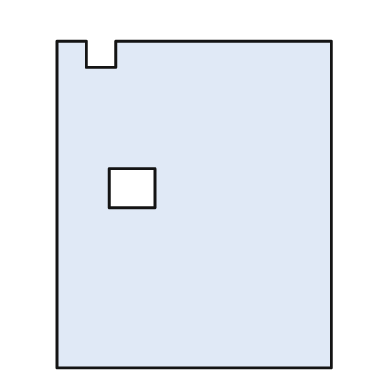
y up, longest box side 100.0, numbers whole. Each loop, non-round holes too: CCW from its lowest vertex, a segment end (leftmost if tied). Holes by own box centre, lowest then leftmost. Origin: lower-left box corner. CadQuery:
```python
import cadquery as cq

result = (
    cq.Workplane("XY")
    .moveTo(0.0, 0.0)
    .lineTo(84.0, 0.0)
    .lineTo(84.0, 100.0)
    .lineTo(18.0, 100.0)
    .lineTo(18.0, 92.0)
    .lineTo(9.0, 92.0)
    .lineTo(9.0, 100.0)
    .lineTo(0.0, 100.0)
    .close()
    .moveTo(16.0, 49.0)
    .lineTo(30.0, 49.0)
    .lineTo(30.0, 61.0)
    .lineTo(16.0, 61.0)
    .close()
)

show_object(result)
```